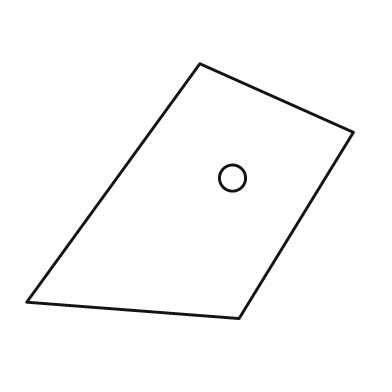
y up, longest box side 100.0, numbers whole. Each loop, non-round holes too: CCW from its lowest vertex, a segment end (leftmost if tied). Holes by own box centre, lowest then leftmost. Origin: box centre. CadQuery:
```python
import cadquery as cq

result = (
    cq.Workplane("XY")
    .moveTo(15.0, -39.0)
    .lineTo(50.0, 18.0)
    .lineTo(3.0, 39.0)
    .lineTo(-50.0, -34.0)
    .close()
    .moveTo(13.0, 4.0)
    .circle(4.0)
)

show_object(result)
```